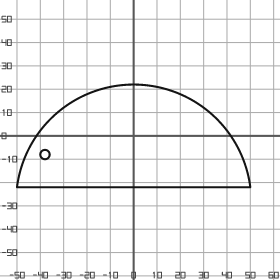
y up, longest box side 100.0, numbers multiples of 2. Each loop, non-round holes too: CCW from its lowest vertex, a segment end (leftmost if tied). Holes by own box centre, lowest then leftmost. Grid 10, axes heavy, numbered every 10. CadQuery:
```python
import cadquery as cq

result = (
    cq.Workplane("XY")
    .moveTo(-50.0, -22.0)
    .lineTo(50.0, -22.0)
    .threePointArc((0.0, 22.0), (-50.0, -22.0))
    .close()
    .moveTo(-38.0, -8.0)
    .circle(2.0)
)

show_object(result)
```